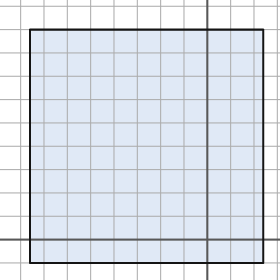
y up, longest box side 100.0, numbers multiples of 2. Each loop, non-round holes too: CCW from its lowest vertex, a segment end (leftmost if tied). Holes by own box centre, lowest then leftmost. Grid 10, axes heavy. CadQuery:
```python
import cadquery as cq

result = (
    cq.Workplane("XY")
    .moveTo(-76.0, -10.0)
    .lineTo(24.0, -10.0)
    .lineTo(24.0, 90.0)
    .lineTo(-76.0, 90.0)
    .close()
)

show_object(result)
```